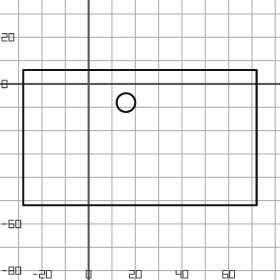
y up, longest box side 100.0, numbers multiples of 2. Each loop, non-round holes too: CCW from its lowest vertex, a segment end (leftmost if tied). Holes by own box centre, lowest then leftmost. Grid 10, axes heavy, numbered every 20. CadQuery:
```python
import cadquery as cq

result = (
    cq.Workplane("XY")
    .moveTo(-28.0, -52.0)
    .lineTo(72.0, -52.0)
    .lineTo(72.0, 6.0)
    .lineTo(-28.0, 6.0)
    .close()
    .moveTo(16.0, -8.0)
    .circle(4.0)
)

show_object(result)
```